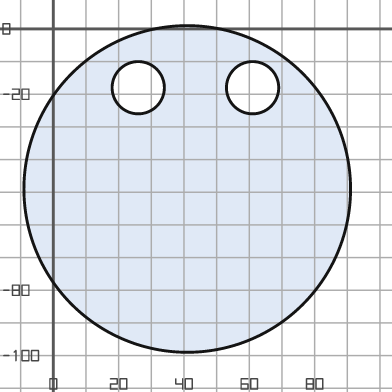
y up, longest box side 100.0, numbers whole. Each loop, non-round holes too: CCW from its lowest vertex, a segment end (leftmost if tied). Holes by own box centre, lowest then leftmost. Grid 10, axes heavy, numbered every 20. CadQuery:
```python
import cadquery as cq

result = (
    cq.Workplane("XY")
    .moveTo(41.0, -49.0)
    .circle(50.0)
    .moveTo(26.0, -18.0)
    .circle(8.0)
    .moveTo(61.0, -18.0)
    .circle(8.0)
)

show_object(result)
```